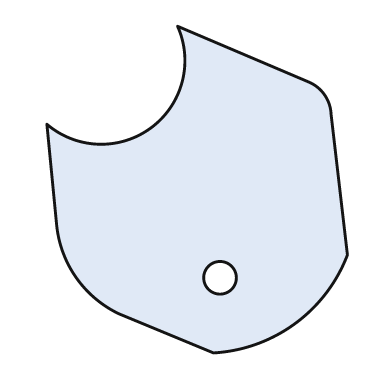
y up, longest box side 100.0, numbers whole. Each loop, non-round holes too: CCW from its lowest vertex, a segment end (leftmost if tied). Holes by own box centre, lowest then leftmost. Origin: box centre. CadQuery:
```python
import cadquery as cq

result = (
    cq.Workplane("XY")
    .moveTo(5.0, -50.0)
    .threePointArc((30.0, -41.0), (46.0, -20.0))
    .lineTo(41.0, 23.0)
    .threePointArc((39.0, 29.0), (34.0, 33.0))
    .lineTo(-6.0, 50.0)
    .threePointArc((-14.0, 19.0), (-46.0, 20.0))
    .lineTo(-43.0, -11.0)
    .threePointArc((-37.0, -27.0), (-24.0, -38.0))
    .close()
    .moveTo(7.0, -27.0)
    .circle(5.0)
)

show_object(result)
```